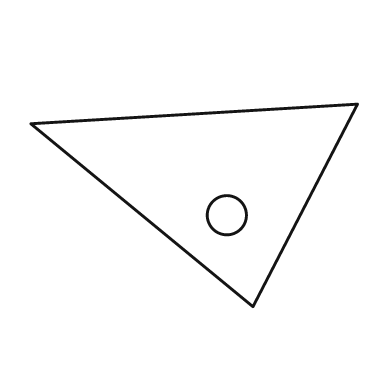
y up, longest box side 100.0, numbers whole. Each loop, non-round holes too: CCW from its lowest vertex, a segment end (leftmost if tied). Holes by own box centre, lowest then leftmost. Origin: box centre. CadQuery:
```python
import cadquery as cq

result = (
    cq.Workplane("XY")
    .moveTo(18.0, -31.0)
    .lineTo(50.0, 31.0)
    .lineTo(-50.0, 25.0)
    .close()
    .moveTo(10.0, -3.0)
    .circle(6.0)
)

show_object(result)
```